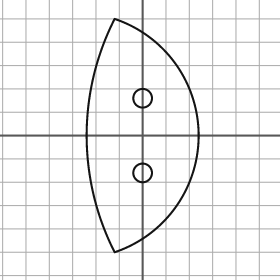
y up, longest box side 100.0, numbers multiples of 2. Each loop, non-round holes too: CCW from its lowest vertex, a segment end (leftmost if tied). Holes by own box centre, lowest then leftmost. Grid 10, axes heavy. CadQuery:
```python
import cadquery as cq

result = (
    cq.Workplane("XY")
    .moveTo(-12.0, -50.0)
    .threePointArc((24.0, 0.0), (-12.0, 50.0))
    .threePointArc((-24.0, 0.0), (-12.0, -50.0))
    .close()
    .moveTo(0.0, -16.0)
    .circle(4.0)
    .moveTo(0.0, 16.0)
    .circle(4.0)
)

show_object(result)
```